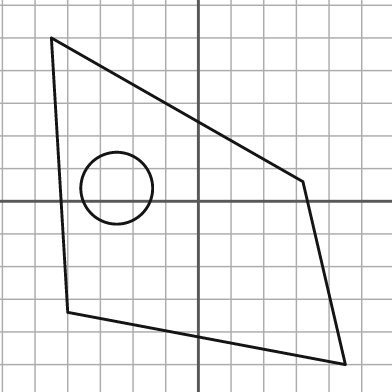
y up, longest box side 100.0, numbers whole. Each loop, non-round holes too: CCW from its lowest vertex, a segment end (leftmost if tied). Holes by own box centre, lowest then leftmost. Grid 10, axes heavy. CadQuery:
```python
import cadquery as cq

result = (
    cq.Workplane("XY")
    .moveTo(45.0, -50.0)
    .lineTo(32.0, 6.0)
    .lineTo(-45.0, 50.0)
    .lineTo(-40.0, -34.0)
    .close()
    .moveTo(-25.0, 4.0)
    .circle(11.0)
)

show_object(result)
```